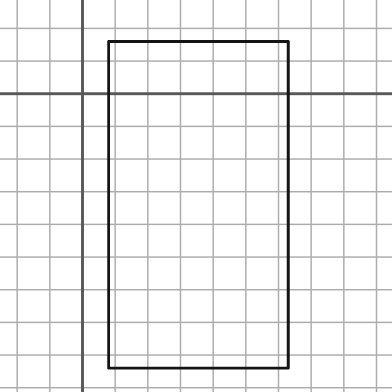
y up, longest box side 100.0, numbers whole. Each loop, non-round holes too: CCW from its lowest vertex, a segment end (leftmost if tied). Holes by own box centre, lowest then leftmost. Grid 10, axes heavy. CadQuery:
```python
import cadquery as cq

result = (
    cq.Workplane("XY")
    .moveTo(8.0, -84.0)
    .lineTo(63.0, -84.0)
    .lineTo(63.0, 16.0)
    .lineTo(8.0, 16.0)
    .close()
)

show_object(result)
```